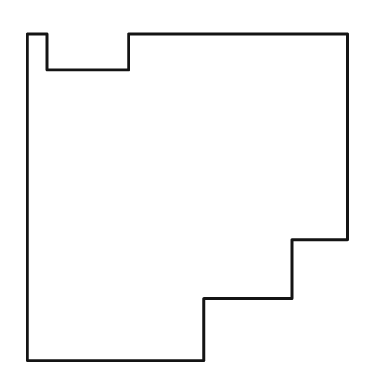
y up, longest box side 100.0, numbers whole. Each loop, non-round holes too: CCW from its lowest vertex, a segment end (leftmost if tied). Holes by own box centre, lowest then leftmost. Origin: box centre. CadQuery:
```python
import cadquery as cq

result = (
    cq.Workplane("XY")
    .moveTo(-49.0, -50.0)
    .lineTo(5.0, -50.0)
    .lineTo(5.0, -31.0)
    .lineTo(32.0, -31.0)
    .lineTo(32.0, -13.0)
    .lineTo(49.0, -13.0)
    .lineTo(49.0, 50.0)
    .lineTo(-18.0, 50.0)
    .lineTo(-18.0, 39.0)
    .lineTo(-43.0, 39.0)
    .lineTo(-43.0, 50.0)
    .lineTo(-49.0, 50.0)
    .close()
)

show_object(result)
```